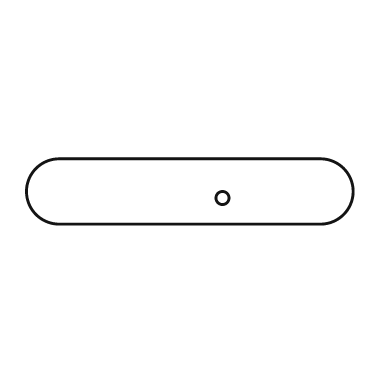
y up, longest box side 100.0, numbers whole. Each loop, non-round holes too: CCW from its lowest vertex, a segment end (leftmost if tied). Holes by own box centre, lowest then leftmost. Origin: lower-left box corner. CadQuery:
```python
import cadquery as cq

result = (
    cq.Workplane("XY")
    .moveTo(10.0, 0.0)
    .lineTo(90.0, 0.0)
    .threePointArc((100.0, 10.0), (90.0, 20.0))
    .lineTo(10.0, 20.0)
    .threePointArc((0.0, 10.0), (10.0, 0.0))
    .close()
    .moveTo(60.0, 8.0)
    .circle(2.0)
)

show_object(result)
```